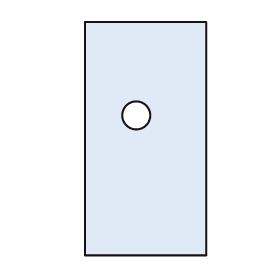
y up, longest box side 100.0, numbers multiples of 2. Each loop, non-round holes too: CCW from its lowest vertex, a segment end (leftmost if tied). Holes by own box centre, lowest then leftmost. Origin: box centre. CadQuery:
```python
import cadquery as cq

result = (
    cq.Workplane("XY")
    .moveTo(-26.0, -50.0)
    .lineTo(26.0, -50.0)
    .lineTo(26.0, 50.0)
    .lineTo(-26.0, 50.0)
    .close()
    .moveTo(-4.0, 10.0)
    .circle(6.0)
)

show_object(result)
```